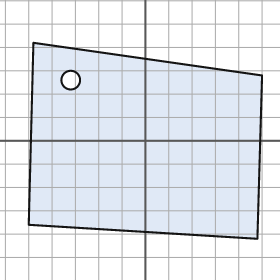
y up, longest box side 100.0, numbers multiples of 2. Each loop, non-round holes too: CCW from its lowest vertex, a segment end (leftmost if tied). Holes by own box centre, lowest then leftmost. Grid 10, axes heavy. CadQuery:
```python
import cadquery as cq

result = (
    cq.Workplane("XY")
    .moveTo(48.0, -42.0)
    .lineTo(50.0, 28.0)
    .lineTo(-48.0, 42.0)
    .lineTo(-50.0, -36.0)
    .close()
    .moveTo(-32.0, 26.0)
    .circle(4.0)
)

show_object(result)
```